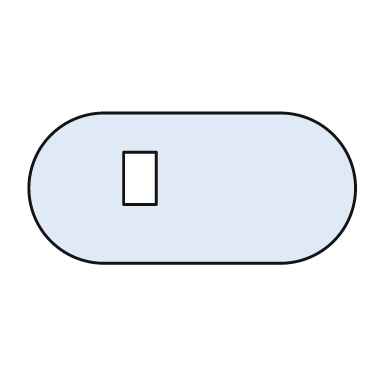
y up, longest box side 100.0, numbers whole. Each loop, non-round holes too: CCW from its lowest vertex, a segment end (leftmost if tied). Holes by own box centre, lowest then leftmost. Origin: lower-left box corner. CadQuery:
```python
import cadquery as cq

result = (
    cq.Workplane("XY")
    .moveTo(23.0, 0.0)
    .lineTo(77.0, 0.0)
    .threePointArc((100.0, 23.0), (77.0, 46.0))
    .lineTo(23.0, 46.0)
    .threePointArc((0.0, 23.0), (23.0, 0.0))
    .close()
    .moveTo(29.0, 18.0)
    .lineTo(39.0, 18.0)
    .lineTo(39.0, 34.0)
    .lineTo(29.0, 34.0)
    .close()
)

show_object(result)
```